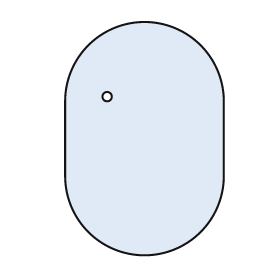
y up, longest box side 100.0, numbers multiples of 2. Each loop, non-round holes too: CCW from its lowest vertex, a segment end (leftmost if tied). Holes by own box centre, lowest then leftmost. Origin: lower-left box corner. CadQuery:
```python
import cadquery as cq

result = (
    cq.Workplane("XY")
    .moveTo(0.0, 34.0)
    .threePointArc((34.0, 0.0), (68.0, 34.0))
    .lineTo(68.0, 66.0)
    .threePointArc((34.0, 100.0), (0.0, 66.0))
    .close()
    .moveTo(18.0, 68.0)
    .circle(2.0)
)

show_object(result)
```